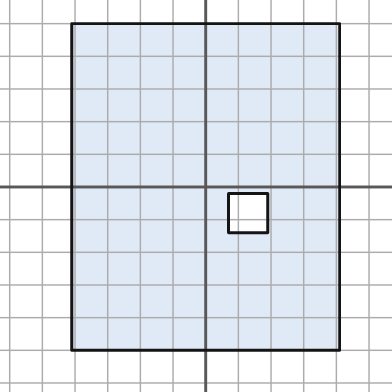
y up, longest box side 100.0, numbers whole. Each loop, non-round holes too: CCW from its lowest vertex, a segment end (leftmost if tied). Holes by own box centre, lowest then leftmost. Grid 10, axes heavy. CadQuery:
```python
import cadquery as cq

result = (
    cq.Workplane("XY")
    .moveTo(-41.0, -50.0)
    .lineTo(41.0, -50.0)
    .lineTo(41.0, 50.0)
    .lineTo(-41.0, 50.0)
    .close()
    .moveTo(7.0, -14.0)
    .lineTo(19.0, -14.0)
    .lineTo(19.0, -2.0)
    .lineTo(7.0, -2.0)
    .close()
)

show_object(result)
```